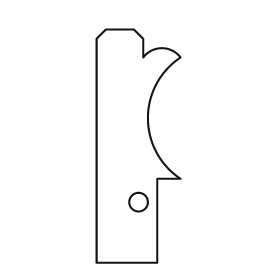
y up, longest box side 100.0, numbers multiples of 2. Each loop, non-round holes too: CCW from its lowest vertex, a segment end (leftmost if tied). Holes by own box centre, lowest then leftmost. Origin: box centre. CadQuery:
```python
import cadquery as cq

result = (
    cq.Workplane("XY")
    .moveTo(-18.0, -50.0)
    .lineTo(8.0, -50.0)
    .lineTo(8.0, -14.0)
    .lineTo(18.0, -14.0)
    .threePointArc((4.0, 12.0), (18.0, 38.0))
    .threePointArc((10.0, 42.0), (2.0, 38.0))
    .lineTo(2.0, 46.0)
    .lineTo(-2.0, 50.0)
    .lineTo(-14.0, 50.0)
    .lineTo(-18.0, 46.0)
    .close()
    .moveTo(0.0, -24.0)
    .circle(4.0)
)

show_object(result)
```